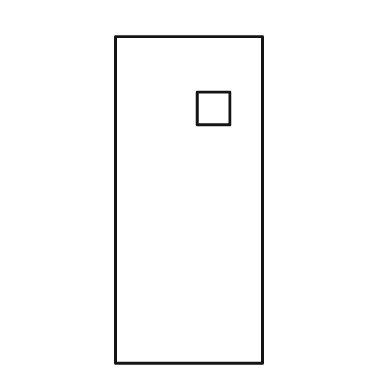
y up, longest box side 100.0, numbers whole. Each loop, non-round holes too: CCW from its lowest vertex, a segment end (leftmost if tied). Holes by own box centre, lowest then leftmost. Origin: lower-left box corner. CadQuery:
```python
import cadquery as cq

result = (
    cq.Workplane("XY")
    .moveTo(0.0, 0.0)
    .lineTo(45.0, 0.0)
    .lineTo(45.0, 100.0)
    .lineTo(0.0, 100.0)
    .close()
    .moveTo(25.0, 73.0)
    .lineTo(35.0, 73.0)
    .lineTo(35.0, 83.0)
    .lineTo(25.0, 83.0)
    .close()
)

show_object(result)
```